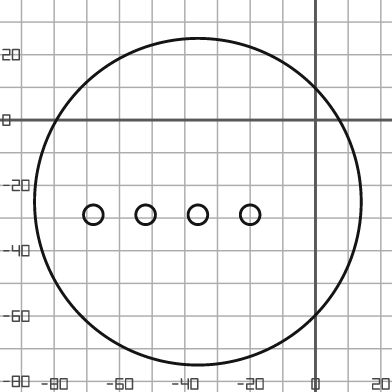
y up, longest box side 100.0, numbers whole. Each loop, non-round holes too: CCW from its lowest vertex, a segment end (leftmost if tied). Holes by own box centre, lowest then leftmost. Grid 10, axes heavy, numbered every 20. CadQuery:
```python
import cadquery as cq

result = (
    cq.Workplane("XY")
    .moveTo(-36.0, -25.0)
    .circle(50.0)
    .moveTo(-68.0, -29.0)
    .circle(3.0)
    .moveTo(-52.0, -29.0)
    .circle(3.0)
    .moveTo(-36.0, -29.0)
    .circle(3.0)
    .moveTo(-20.0, -29.0)
    .circle(3.0)
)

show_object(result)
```